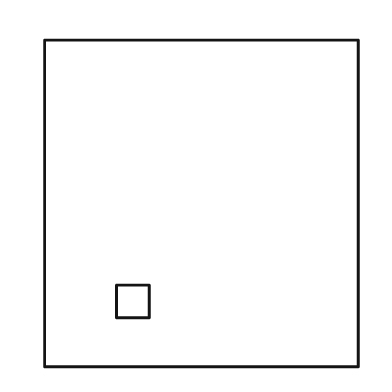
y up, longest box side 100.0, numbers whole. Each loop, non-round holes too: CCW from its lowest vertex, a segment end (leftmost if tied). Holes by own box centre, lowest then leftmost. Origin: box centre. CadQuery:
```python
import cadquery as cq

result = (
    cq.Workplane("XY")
    .moveTo(-48.0, -50.0)
    .lineTo(48.0, -50.0)
    .lineTo(48.0, 50.0)
    .lineTo(-48.0, 50.0)
    .close()
    .moveTo(-26.0, -35.0)
    .lineTo(-16.0, -35.0)
    .lineTo(-16.0, -25.0)
    .lineTo(-26.0, -25.0)
    .close()
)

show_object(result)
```